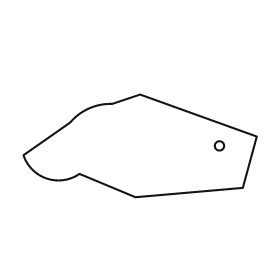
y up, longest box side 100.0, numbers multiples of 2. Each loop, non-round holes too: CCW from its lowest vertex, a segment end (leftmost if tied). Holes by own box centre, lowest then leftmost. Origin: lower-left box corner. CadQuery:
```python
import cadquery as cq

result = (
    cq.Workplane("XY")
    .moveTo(48.0, 0.0)
    .lineTo(94.0, 4.0)
    .lineTo(100.0, 26.0)
    .lineTo(50.0, 44.0)
    .lineTo(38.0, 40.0)
    .threePointArc((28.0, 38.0), (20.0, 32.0))
    .lineTo(0.0, 18.0)
    .threePointArc((10.0, 8.0), (24.0, 10.0))
    .close()
    .moveTo(84.0, 22.0)
    .circle(2.0)
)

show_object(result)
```